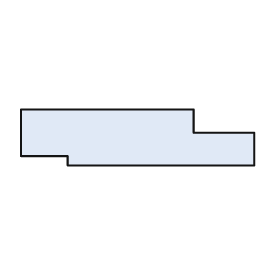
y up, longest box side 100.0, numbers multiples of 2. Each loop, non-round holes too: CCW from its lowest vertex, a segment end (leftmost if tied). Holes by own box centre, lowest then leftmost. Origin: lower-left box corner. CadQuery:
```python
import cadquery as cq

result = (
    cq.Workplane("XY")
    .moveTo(20.0, 0.0)
    .lineTo(100.0, 0.0)
    .lineTo(100.0, 14.0)
    .lineTo(74.0, 14.0)
    .lineTo(74.0, 24.0)
    .lineTo(0.0, 24.0)
    .lineTo(0.0, 4.0)
    .lineTo(20.0, 4.0)
    .close()
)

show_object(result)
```